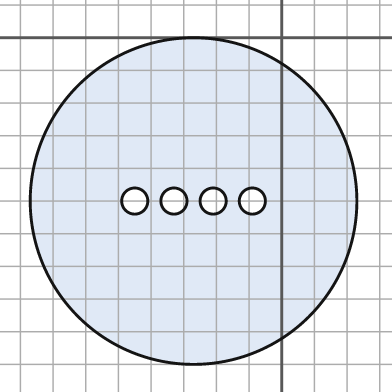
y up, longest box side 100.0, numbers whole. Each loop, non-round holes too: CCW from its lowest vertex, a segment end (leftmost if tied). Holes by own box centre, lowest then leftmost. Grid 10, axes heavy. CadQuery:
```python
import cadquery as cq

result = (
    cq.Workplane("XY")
    .moveTo(-27.0, -50.0)
    .circle(50.0)
    .moveTo(-45.0, -50.0)
    .circle(4.0)
    .moveTo(-33.0, -50.0)
    .circle(4.0)
    .moveTo(-21.0, -50.0)
    .circle(4.0)
    .moveTo(-9.0, -50.0)
    .circle(4.0)
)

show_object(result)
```